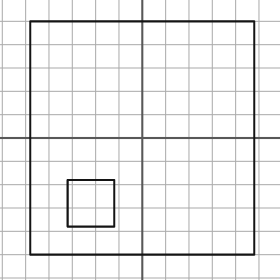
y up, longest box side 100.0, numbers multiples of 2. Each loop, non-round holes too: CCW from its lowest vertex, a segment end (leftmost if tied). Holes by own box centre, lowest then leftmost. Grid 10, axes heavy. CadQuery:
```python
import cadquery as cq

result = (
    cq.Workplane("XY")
    .moveTo(-48.0, -50.0)
    .lineTo(48.0, -50.0)
    .lineTo(48.0, 50.0)
    .lineTo(-48.0, 50.0)
    .close()
    .moveTo(-32.0, -38.0)
    .lineTo(-12.0, -38.0)
    .lineTo(-12.0, -18.0)
    .lineTo(-32.0, -18.0)
    .close()
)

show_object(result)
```